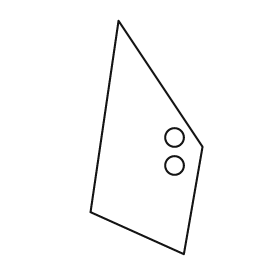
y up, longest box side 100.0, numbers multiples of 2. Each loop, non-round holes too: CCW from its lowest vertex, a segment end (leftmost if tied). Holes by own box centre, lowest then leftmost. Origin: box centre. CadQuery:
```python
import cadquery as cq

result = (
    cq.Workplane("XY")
    .moveTo(16.0, -50.0)
    .lineTo(24.0, -4.0)
    .lineTo(-12.0, 50.0)
    .lineTo(-24.0, -32.0)
    .close()
    .moveTo(12.0, -12.0)
    .circle(4.0)
    .moveTo(12.0, 0.0)
    .circle(4.0)
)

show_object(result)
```